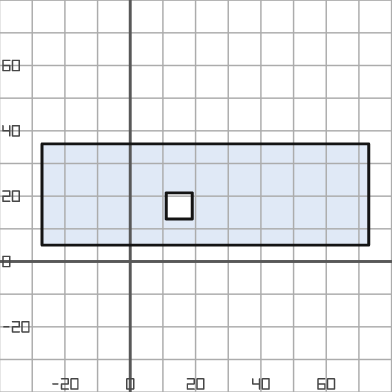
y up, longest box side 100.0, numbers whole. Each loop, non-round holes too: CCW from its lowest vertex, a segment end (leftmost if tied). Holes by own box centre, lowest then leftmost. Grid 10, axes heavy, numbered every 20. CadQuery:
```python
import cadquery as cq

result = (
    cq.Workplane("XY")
    .moveTo(-27.0, 5.0)
    .lineTo(73.0, 5.0)
    .lineTo(73.0, 36.0)
    .lineTo(-27.0, 36.0)
    .close()
    .moveTo(11.0, 13.0)
    .lineTo(19.0, 13.0)
    .lineTo(19.0, 21.0)
    .lineTo(11.0, 21.0)
    .close()
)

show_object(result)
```